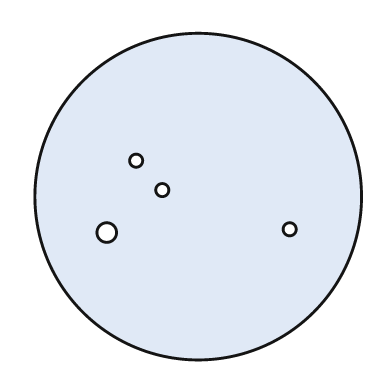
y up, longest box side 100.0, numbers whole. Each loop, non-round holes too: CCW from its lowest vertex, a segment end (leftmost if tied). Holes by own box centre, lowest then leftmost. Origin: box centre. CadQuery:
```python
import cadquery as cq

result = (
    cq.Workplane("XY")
    .moveTo(0.0, 0.0)
    .circle(50.0)
    .moveTo(-28.0, -11.0)
    .circle(3.0)
    .moveTo(28.0, -10.0)
    .circle(2.0)
    .moveTo(-11.0, 2.0)
    .circle(2.0)
    .moveTo(-19.0, 11.0)
    .circle(2.0)
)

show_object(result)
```